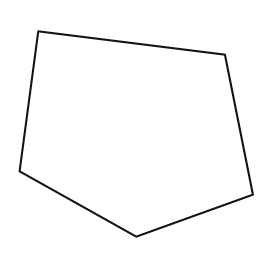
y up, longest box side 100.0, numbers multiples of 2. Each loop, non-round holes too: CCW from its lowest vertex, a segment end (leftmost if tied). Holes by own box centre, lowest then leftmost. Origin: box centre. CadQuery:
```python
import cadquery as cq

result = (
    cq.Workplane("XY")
    .moveTo(0.0, -44.0)
    .lineTo(50.0, -26.0)
    .lineTo(38.0, 34.0)
    .lineTo(-42.0, 44.0)
    .lineTo(-50.0, -16.0)
    .close()
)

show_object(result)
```